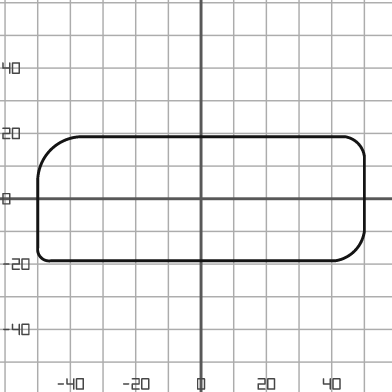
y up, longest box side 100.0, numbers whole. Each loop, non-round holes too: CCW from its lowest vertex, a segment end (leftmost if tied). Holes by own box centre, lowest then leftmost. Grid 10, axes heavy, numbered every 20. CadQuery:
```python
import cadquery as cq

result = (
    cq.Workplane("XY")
    .moveTo(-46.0, -19.0)
    .lineTo(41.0, -19.0)
    .threePointArc((47.0, -16.0), (50.0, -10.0))
    .lineTo(50.0, 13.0)
    .threePointArc((48.0, 17.0), (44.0, 19.0))
    .lineTo(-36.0, 19.0)
    .threePointArc((-46.0, 15.0), (-50.0, 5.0))
    .lineTo(-50.0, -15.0)
    .threePointArc((-49.0, -18.0), (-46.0, -19.0))
    .close()
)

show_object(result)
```